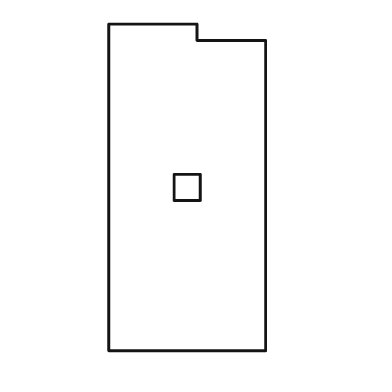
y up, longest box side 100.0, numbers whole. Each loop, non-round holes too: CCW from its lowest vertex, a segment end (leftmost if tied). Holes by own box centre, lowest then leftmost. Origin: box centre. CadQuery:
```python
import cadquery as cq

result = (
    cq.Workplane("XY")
    .moveTo(-24.0, -50.0)
    .lineTo(24.0, -50.0)
    .lineTo(24.0, 45.0)
    .lineTo(3.0, 45.0)
    .lineTo(3.0, 50.0)
    .lineTo(-24.0, 50.0)
    .close()
    .moveTo(-4.0, -4.0)
    .lineTo(4.0, -4.0)
    .lineTo(4.0, 4.0)
    .lineTo(-4.0, 4.0)
    .close()
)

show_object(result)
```